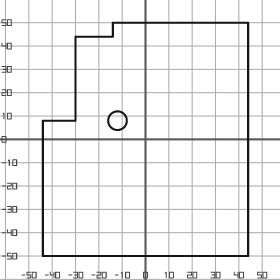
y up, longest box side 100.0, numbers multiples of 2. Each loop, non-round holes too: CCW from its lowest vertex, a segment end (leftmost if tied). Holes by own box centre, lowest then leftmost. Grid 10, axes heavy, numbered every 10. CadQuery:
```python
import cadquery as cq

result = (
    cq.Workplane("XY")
    .moveTo(-44.0, -50.0)
    .lineTo(44.0, -50.0)
    .lineTo(44.0, 50.0)
    .lineTo(-14.0, 50.0)
    .lineTo(-14.0, 44.0)
    .lineTo(-30.0, 44.0)
    .lineTo(-30.0, 8.0)
    .lineTo(-44.0, 8.0)
    .close()
    .moveTo(-12.0, 8.0)
    .circle(4.0)
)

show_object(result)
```